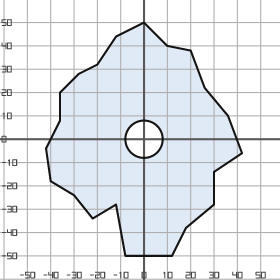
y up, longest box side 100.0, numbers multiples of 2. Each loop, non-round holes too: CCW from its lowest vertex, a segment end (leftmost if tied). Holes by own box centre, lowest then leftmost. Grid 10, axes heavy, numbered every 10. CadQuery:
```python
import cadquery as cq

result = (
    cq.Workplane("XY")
    .moveTo(-8.0, -50.0)
    .lineTo(12.0, -50.0)
    .lineTo(18.0, -38.0)
    .lineTo(30.0, -28.0)
    .lineTo(30.0, -14.0)
    .lineTo(42.0, -6.0)
    .lineTo(36.0, 10.0)
    .lineTo(26.0, 22.0)
    .lineTo(20.0, 38.0)
    .lineTo(10.0, 40.0)
    .lineTo(0.0, 50.0)
    .lineTo(-12.0, 44.0)
    .lineTo(-20.0, 32.0)
    .lineTo(-28.0, 28.0)
    .lineTo(-36.0, 20.0)
    .lineTo(-36.0, 8.0)
    .lineTo(-42.0, -4.0)
    .lineTo(-40.0, -18.0)
    .lineTo(-30.0, -24.0)
    .lineTo(-22.0, -34.0)
    .lineTo(-12.0, -28.0)
    .close()
    .moveTo(0.0, 0.0)
    .circle(8.0)
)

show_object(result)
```